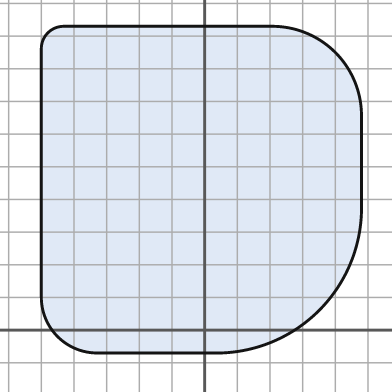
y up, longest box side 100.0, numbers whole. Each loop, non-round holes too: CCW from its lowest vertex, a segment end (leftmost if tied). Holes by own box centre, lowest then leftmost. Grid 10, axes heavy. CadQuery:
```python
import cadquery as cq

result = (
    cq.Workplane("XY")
    .moveTo(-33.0, -7.0)
    .lineTo(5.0, -7.0)
    .threePointArc((35.0, 6.0), (48.0, 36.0))
    .lineTo(48.0, 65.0)
    .threePointArc((40.0, 85.0), (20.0, 93.0))
    .lineTo(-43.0, 93.0)
    .threePointArc((-48.0, 91.0), (-50.0, 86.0))
    .lineTo(-50.0, 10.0)
    .threePointArc((-45.0, -2.0), (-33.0, -7.0))
    .close()
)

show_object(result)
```